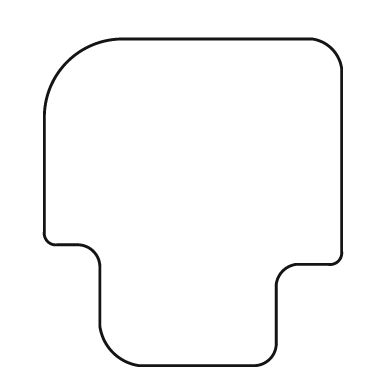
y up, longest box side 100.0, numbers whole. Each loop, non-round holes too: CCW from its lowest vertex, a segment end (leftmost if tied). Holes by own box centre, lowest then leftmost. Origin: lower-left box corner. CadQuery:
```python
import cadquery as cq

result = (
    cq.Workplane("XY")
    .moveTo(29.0, 0.0)
    .lineTo(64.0, 0.0)
    .threePointArc((69.0, 2.0), (71.0, 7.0))
    .lineTo(71.0, 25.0)
    .threePointArc((73.0, 29.0), (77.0, 31.0))
    .lineTo(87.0, 31.0)
    .threePointArc((90.0, 32.0), (91.0, 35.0))
    .lineTo(91.0, 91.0)
    .threePointArc((88.0, 97.0), (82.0, 100.0))
    .lineTo(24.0, 100.0)
    .threePointArc((7.0, 93.0), (0.0, 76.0))
    .lineTo(0.0, 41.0)
    .threePointArc((1.0, 38.0), (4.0, 37.0))
    .lineTo(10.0, 37.0)
    .threePointArc((15.0, 35.0), (17.0, 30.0))
    .lineTo(17.0, 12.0)
    .threePointArc((21.0, 4.0), (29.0, 0.0))
    .close()
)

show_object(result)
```